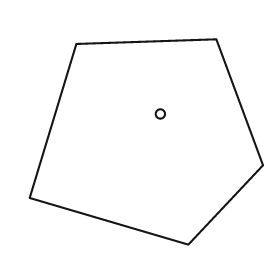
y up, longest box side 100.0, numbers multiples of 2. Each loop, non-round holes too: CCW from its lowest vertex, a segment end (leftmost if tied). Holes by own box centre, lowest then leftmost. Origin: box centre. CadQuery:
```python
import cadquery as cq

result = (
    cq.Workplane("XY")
    .moveTo(18.0, -44.0)
    .lineTo(50.0, -10.0)
    .lineTo(30.0, 44.0)
    .lineTo(-30.0, 42.0)
    .lineTo(-50.0, -24.0)
    .close()
    .moveTo(6.0, 12.0)
    .circle(2.0)
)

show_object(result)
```